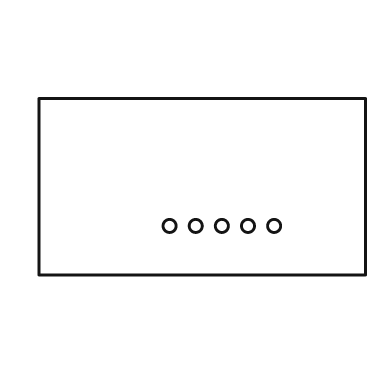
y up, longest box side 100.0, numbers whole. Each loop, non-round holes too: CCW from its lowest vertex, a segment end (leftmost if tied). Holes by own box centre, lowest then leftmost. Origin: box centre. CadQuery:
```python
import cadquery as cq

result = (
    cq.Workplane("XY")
    .moveTo(-50.0, -27.0)
    .lineTo(50.0, -27.0)
    .lineTo(50.0, 27.0)
    .lineTo(-50.0, 27.0)
    .close()
    .moveTo(-10.0, -12.0)
    .circle(2.0)
    .moveTo(-2.0, -12.0)
    .circle(2.0)
    .moveTo(6.0, -12.0)
    .circle(2.0)
    .moveTo(14.0, -12.0)
    .circle(2.0)
    .moveTo(22.0, -12.0)
    .circle(2.0)
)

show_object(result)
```